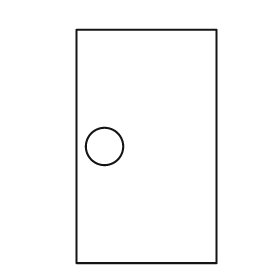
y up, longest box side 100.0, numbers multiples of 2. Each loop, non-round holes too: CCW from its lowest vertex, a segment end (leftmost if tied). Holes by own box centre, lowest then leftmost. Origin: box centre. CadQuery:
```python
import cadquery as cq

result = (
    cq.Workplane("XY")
    .moveTo(-30.0, -50.0)
    .lineTo(30.0, -50.0)
    .lineTo(30.0, 50.0)
    .lineTo(-30.0, 50.0)
    .close()
    .moveTo(-18.0, 0.0)
    .circle(8.0)
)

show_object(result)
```